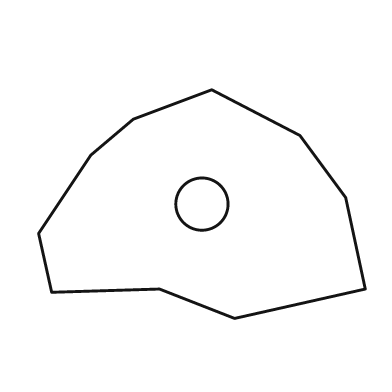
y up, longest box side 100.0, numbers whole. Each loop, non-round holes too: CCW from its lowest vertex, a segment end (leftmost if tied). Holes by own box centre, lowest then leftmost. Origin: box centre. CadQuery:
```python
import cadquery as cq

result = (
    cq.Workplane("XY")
    .moveTo(10.0, -35.0)
    .lineTo(50.0, -26.0)
    .lineTo(44.0, 2.0)
    .lineTo(30.0, 21.0)
    .lineTo(3.0, 35.0)
    .lineTo(-21.0, 26.0)
    .lineTo(-34.0, 15.0)
    .lineTo(-50.0, -9.0)
    .lineTo(-46.0, -27.0)
    .lineTo(-13.0, -26.0)
    .close()
    .moveTo(0.0, 0.0)
    .circle(8.0)
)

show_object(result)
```